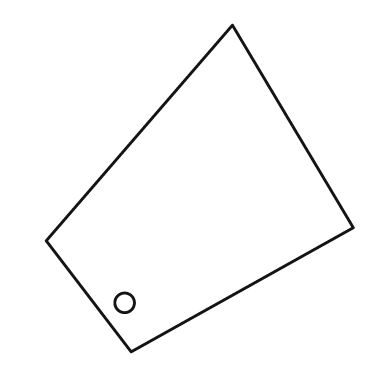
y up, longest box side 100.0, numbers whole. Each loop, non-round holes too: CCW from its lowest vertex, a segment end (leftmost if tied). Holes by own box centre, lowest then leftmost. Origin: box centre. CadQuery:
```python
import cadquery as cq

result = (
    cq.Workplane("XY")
    .moveTo(-21.0, -50.0)
    .lineTo(47.0, -12.0)
    .lineTo(10.0, 50.0)
    .lineTo(-47.0, -16.0)
    .close()
    .moveTo(-23.0, -35.0)
    .circle(3.0)
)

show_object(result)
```